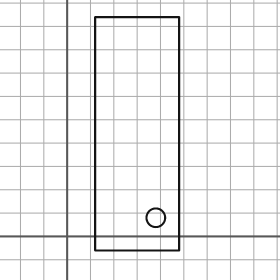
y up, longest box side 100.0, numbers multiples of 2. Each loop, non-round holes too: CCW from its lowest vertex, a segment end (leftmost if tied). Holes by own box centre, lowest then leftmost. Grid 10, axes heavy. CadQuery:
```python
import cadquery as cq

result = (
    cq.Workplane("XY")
    .moveTo(12.0, -6.0)
    .lineTo(48.0, -6.0)
    .lineTo(48.0, 94.0)
    .lineTo(12.0, 94.0)
    .close()
    .moveTo(38.0, 8.0)
    .circle(4.0)
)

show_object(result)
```